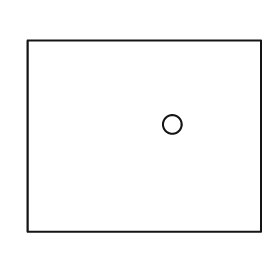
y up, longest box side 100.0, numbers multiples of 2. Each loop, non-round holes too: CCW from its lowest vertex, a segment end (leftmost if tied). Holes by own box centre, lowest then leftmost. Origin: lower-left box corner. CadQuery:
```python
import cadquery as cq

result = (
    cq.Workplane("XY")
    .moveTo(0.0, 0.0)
    .lineTo(100.0, 0.0)
    .lineTo(100.0, 82.0)
    .lineTo(0.0, 82.0)
    .close()
    .moveTo(62.0, 46.0)
    .circle(4.0)
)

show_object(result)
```